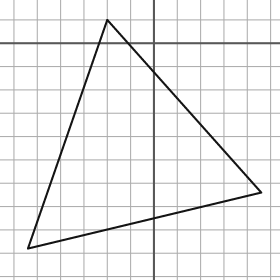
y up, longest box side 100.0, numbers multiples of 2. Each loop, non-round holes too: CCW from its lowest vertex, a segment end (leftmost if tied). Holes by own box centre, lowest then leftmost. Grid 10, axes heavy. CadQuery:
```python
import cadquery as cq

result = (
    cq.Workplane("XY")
    .moveTo(-54.0, -88.0)
    .lineTo(46.0, -64.0)
    .lineTo(-20.0, 10.0)
    .close()
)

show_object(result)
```